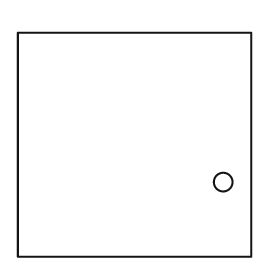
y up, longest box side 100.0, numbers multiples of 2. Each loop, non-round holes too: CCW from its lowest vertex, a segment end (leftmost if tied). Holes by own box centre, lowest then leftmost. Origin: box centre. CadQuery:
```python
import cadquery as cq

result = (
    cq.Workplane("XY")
    .moveTo(-50.0, -48.0)
    .lineTo(50.0, -48.0)
    .lineTo(50.0, 48.0)
    .lineTo(-50.0, 48.0)
    .close()
    .moveTo(38.0, -16.0)
    .circle(4.0)
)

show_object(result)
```